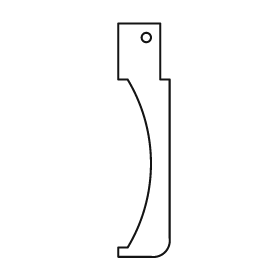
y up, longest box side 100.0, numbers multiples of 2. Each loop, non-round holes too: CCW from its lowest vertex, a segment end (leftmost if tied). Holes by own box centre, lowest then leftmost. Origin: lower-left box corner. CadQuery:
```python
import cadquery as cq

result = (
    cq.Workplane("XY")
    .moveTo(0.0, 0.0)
    .lineTo(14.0, 0.0)
    .threePointArc((20.0, 2.0), (22.0, 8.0))
    .lineTo(22.0, 76.0)
    .lineTo(18.0, 76.0)
    .lineTo(18.0, 100.0)
    .lineTo(0.0, 100.0)
    .lineTo(0.0, 76.0)
    .lineTo(4.0, 76.0)
    .threePointArc((14.0, 40.0), (4.0, 4.0))
    .lineTo(0.0, 4.0)
    .close()
    .moveTo(12.0, 94.0)
    .circle(2.0)
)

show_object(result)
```